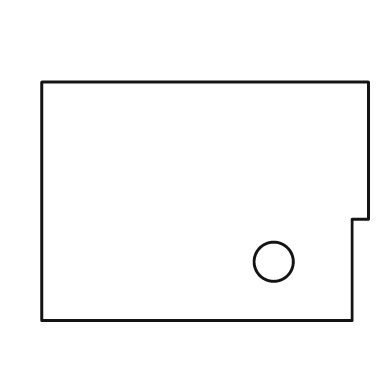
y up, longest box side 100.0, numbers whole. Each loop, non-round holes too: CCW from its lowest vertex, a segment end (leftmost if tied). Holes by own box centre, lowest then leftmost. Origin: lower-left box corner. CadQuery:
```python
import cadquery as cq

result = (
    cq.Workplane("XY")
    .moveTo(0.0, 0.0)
    .lineTo(95.0, 0.0)
    .lineTo(95.0, 31.0)
    .lineTo(100.0, 31.0)
    .lineTo(100.0, 73.0)
    .lineTo(0.0, 73.0)
    .close()
    .moveTo(71.0, 18.0)
    .circle(6.0)
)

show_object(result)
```